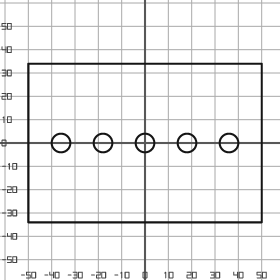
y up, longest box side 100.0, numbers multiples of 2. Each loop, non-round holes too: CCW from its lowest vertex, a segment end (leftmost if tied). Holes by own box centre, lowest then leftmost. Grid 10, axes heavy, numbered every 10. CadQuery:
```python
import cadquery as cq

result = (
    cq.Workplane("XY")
    .moveTo(-50.0, -34.0)
    .lineTo(50.0, -34.0)
    .lineTo(50.0, 34.0)
    .lineTo(-50.0, 34.0)
    .close()
    .moveTo(-36.0, 0.0)
    .circle(4.0)
    .moveTo(-18.0, 0.0)
    .circle(4.0)
    .moveTo(0.0, 0.0)
    .circle(4.0)
    .moveTo(18.0, 0.0)
    .circle(4.0)
    .moveTo(36.0, 0.0)
    .circle(4.0)
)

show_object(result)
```